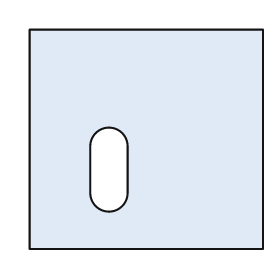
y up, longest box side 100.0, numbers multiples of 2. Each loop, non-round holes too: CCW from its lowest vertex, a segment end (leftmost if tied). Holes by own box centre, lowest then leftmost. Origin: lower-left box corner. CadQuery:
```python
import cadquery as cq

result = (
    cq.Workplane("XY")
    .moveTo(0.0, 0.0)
    .lineTo(100.0, 0.0)
    .lineTo(100.0, 94.0)
    .lineTo(0.0, 94.0)
    .close()
    .moveTo(26.0, 24.0)
    .threePointArc((34.0, 16.0), (42.0, 24.0))
    .lineTo(42.0, 44.0)
    .threePointArc((34.0, 52.0), (26.0, 44.0))
    .close()
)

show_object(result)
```